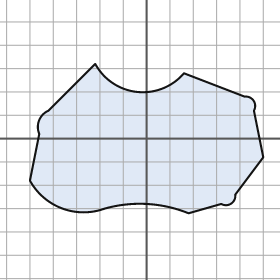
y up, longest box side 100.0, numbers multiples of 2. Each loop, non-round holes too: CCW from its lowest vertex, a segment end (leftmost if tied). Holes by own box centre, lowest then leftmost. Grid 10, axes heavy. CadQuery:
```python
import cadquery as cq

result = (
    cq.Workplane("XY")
    .moveTo(18.0, -32.0)
    .lineTo(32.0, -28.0)
    .threePointArc((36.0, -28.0), (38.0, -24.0))
    .lineTo(50.0, -8.0)
    .lineTo(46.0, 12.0)
    .threePointArc((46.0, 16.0), (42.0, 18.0))
    .lineTo(16.0, 28.0)
    .threePointArc((-4.0, 20.0), (-22.0, 32.0))
    .lineTo(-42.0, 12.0)
    .threePointArc((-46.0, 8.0), (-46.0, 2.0))
    .lineTo(-50.0, -18.0)
    .threePointArc((-36.0, -30.0), (-18.0, -30.0))
    .threePointArc((0.0, -28.0), (18.0, -32.0))
    .close()
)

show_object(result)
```